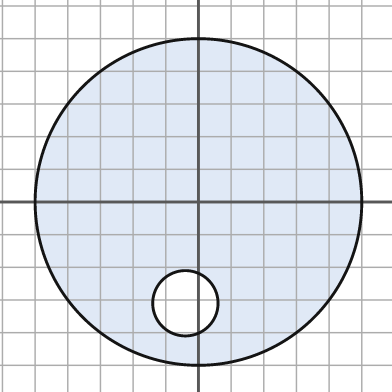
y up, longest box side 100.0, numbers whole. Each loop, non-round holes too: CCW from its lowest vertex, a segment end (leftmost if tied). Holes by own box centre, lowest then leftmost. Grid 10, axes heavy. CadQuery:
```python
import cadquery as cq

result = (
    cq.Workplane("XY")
    .moveTo(0.0, 0.0)
    .circle(50.0)
    .moveTo(-4.0, -31.0)
    .circle(10.0)
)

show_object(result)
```